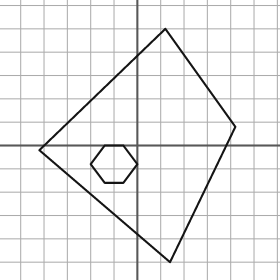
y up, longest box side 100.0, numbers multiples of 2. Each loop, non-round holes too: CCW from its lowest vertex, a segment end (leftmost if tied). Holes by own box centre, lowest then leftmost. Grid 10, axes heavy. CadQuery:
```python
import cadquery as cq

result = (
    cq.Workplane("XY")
    .moveTo(14.0, -50.0)
    .lineTo(42.0, 8.0)
    .lineTo(12.0, 50.0)
    .lineTo(-42.0, -2.0)
    .close()
    .moveTo(-14.0, -16.0)
    .lineTo(-6.0, -16.0)
    .lineTo(0.0, -8.0)
    .lineTo(-6.0, 0.0)
    .lineTo(-14.0, 0.0)
    .lineTo(-20.0, -8.0)
    .close()
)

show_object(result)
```